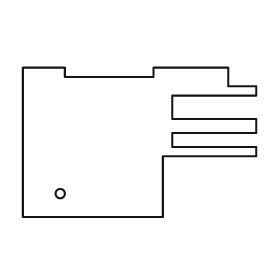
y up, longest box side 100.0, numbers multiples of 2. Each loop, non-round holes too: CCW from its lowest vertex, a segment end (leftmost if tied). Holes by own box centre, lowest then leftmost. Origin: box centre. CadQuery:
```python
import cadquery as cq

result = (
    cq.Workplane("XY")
    .moveTo(-50.0, -32.0)
    .lineTo(10.0, -32.0)
    .lineTo(10.0, -6.0)
    .lineTo(50.0, -6.0)
    .lineTo(50.0, -2.0)
    .lineTo(14.0, -2.0)
    .lineTo(14.0, 4.0)
    .lineTo(50.0, 4.0)
    .lineTo(50.0, 10.0)
    .lineTo(14.0, 10.0)
    .lineTo(14.0, 20.0)
    .lineTo(50.0, 20.0)
    .lineTo(50.0, 24.0)
    .lineTo(38.0, 24.0)
    .lineTo(38.0, 32.0)
    .lineTo(6.0, 32.0)
    .lineTo(6.0, 28.0)
    .lineTo(-32.0, 28.0)
    .lineTo(-32.0, 32.0)
    .lineTo(-50.0, 32.0)
    .close()
    .moveTo(-34.0, -22.0)
    .circle(2.0)
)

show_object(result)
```